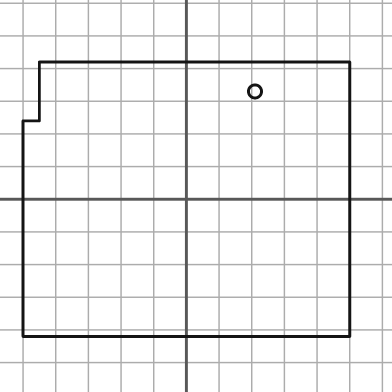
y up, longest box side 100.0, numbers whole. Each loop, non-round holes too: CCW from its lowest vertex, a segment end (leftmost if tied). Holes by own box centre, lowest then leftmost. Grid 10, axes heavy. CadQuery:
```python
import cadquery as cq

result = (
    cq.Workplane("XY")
    .moveTo(-50.0, -42.0)
    .lineTo(50.0, -42.0)
    .lineTo(50.0, 42.0)
    .lineTo(-45.0, 42.0)
    .lineTo(-45.0, 24.0)
    .lineTo(-50.0, 24.0)
    .close()
    .moveTo(21.0, 33.0)
    .circle(2.0)
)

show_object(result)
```